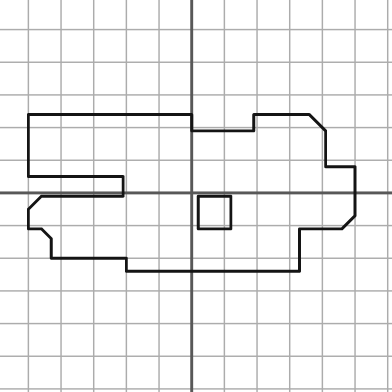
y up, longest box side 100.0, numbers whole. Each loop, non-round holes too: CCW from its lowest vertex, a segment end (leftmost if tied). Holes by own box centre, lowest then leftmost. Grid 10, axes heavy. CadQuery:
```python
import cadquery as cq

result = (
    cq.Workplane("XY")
    .moveTo(-20.0, -24.0)
    .lineTo(33.0, -24.0)
    .lineTo(33.0, -11.0)
    .lineTo(46.0, -11.0)
    .lineTo(50.0, -7.0)
    .lineTo(50.0, 8.0)
    .lineTo(41.0, 8.0)
    .lineTo(41.0, 19.0)
    .lineTo(36.0, 24.0)
    .lineTo(19.0, 24.0)
    .lineTo(19.0, 19.0)
    .lineTo(0.0, 19.0)
    .lineTo(0.0, 24.0)
    .lineTo(-50.0, 24.0)
    .lineTo(-50.0, 5.0)
    .lineTo(-21.0, 5.0)
    .lineTo(-21.0, -1.0)
    .lineTo(-46.0, -1.0)
    .lineTo(-50.0, -5.0)
    .lineTo(-50.0, -11.0)
    .lineTo(-46.0, -11.0)
    .lineTo(-43.0, -14.0)
    .lineTo(-43.0, -20.0)
    .lineTo(-20.0, -20.0)
    .close()
    .moveTo(2.0, -11.0)
    .lineTo(12.0, -11.0)
    .lineTo(12.0, -1.0)
    .lineTo(2.0, -1.0)
    .close()
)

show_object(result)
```